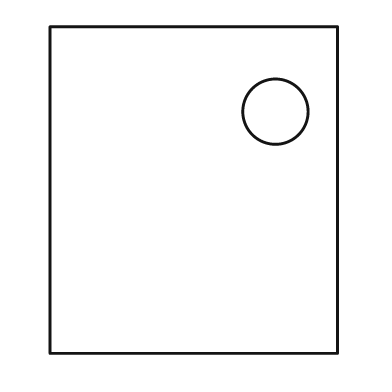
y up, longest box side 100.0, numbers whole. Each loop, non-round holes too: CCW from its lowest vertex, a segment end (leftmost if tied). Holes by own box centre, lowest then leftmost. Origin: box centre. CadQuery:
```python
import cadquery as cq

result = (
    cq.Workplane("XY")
    .moveTo(-44.0, -50.0)
    .lineTo(44.0, -50.0)
    .lineTo(44.0, 50.0)
    .lineTo(-44.0, 50.0)
    .close()
    .moveTo(25.0, 24.0)
    .circle(10.0)
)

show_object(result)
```